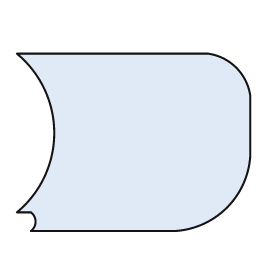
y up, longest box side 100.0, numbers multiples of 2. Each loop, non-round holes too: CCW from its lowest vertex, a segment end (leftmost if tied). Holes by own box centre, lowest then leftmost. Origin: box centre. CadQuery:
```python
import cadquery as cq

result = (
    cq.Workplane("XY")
    .moveTo(-44.0, -38.0)
    .lineTo(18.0, -38.0)
    .threePointArc((40.0, -28.0), (50.0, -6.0))
    .lineTo(50.0, 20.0)
    .threePointArc((44.0, 32.0), (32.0, 38.0))
    .lineTo(-50.0, 38.0)
    .threePointArc((-34.0, 4.0), (-50.0, -30.0))
    .lineTo(-44.0, -30.0)
    .threePointArc((-42.0, -34.0), (-44.0, -38.0))
    .close()
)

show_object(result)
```